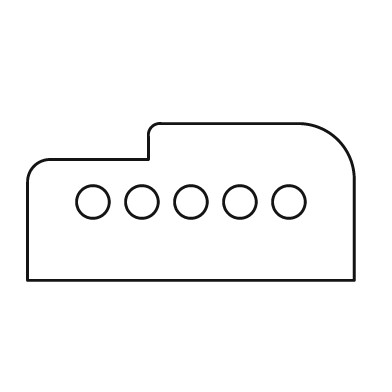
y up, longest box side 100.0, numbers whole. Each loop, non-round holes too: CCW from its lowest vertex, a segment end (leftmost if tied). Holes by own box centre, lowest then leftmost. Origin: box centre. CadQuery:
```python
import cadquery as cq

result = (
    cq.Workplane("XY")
    .moveTo(-50.0, -24.0)
    .lineTo(50.0, -24.0)
    .lineTo(50.0, 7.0)
    .threePointArc((45.0, 19.0), (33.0, 24.0))
    .lineTo(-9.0, 24.0)
    .threePointArc((-12.0, 23.0), (-13.0, 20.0))
    .lineTo(-13.0, 13.0)
    .lineTo(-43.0, 13.0)
    .threePointArc((-48.0, 11.0), (-50.0, 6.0))
    .close()
    .moveTo(-30.0, 0.0)
    .circle(5.0)
    .moveTo(-15.0, 0.0)
    .circle(5.0)
    .moveTo(0.0, 0.0)
    .circle(5.0)
    .moveTo(15.0, 0.0)
    .circle(5.0)
    .moveTo(30.0, 0.0)
    .circle(5.0)
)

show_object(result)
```